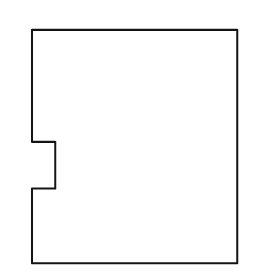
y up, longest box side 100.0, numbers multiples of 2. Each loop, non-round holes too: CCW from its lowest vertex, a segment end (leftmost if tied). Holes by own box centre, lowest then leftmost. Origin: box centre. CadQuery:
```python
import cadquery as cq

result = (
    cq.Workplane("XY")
    .moveTo(-44.0, -50.0)
    .lineTo(44.0, -50.0)
    .lineTo(44.0, 50.0)
    .lineTo(-44.0, 50.0)
    .lineTo(-44.0, 2.0)
    .lineTo(-34.0, 2.0)
    .lineTo(-34.0, -18.0)
    .lineTo(-44.0, -18.0)
    .close()
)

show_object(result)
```